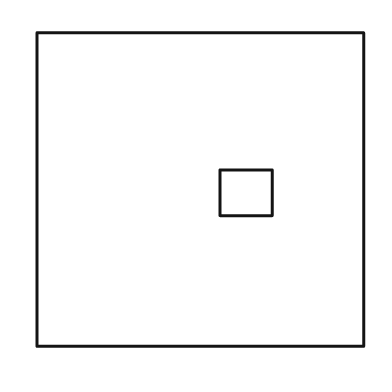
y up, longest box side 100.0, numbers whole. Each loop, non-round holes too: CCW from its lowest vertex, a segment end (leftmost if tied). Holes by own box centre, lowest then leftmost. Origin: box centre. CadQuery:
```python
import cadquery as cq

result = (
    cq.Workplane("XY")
    .moveTo(-50.0, -48.0)
    .lineTo(50.0, -48.0)
    .lineTo(50.0, 48.0)
    .lineTo(-50.0, 48.0)
    .close()
    .moveTo(6.0, -8.0)
    .lineTo(22.0, -8.0)
    .lineTo(22.0, 6.0)
    .lineTo(6.0, 6.0)
    .close()
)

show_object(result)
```